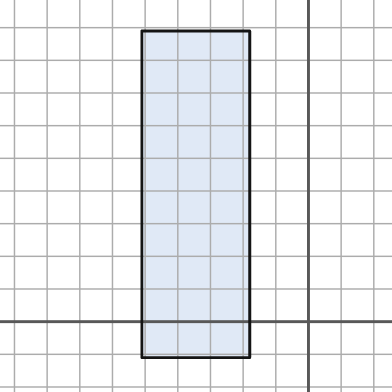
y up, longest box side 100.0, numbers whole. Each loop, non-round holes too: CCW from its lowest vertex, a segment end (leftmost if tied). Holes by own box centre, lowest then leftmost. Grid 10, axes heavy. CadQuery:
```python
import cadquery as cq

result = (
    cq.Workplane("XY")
    .moveTo(-51.0, -11.0)
    .lineTo(-18.0, -11.0)
    .lineTo(-18.0, 89.0)
    .lineTo(-51.0, 89.0)
    .close()
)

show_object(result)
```